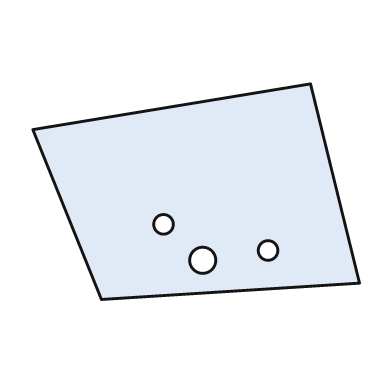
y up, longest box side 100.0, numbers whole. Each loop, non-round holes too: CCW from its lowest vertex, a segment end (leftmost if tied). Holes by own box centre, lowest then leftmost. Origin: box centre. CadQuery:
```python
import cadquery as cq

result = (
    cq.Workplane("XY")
    .moveTo(-29.0, -33.0)
    .lineTo(50.0, -28.0)
    .lineTo(35.0, 33.0)
    .lineTo(-50.0, 19.0)
    .close()
    .moveTo(2.0, -21.0)
    .circle(4.0)
    .moveTo(22.0, -18.0)
    .circle(3.0)
    .moveTo(-10.0, -10.0)
    .circle(3.0)
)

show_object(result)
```